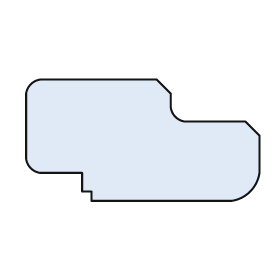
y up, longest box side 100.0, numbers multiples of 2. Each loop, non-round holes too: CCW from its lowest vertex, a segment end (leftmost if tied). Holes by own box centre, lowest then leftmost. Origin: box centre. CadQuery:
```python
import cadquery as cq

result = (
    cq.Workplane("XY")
    .moveTo(-22.0, -26.0)
    .lineTo(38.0, -26.0)
    .threePointArc((46.0, -22.0), (50.0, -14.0))
    .lineTo(50.0, 2.0)
    .lineTo(44.0, 8.0)
    .lineTo(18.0, 8.0)
    .threePointArc((14.0, 10.0), (12.0, 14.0))
    .lineTo(12.0, 20.0)
    .lineTo(6.0, 26.0)
    .lineTo(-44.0, 26.0)
    .threePointArc((-48.0, 24.0), (-50.0, 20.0))
    .lineTo(-50.0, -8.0)
    .threePointArc((-48.0, -12.0), (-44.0, -14.0))
    .lineTo(-26.0, -14.0)
    .lineTo(-26.0, -22.0)
    .lineTo(-22.0, -22.0)
    .close()
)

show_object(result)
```